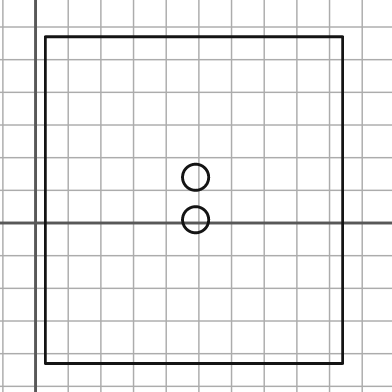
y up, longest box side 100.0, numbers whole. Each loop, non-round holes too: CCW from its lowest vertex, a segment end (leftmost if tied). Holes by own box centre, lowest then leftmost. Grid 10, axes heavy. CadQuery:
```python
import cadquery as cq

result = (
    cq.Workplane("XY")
    .moveTo(3.0, -43.0)
    .lineTo(94.0, -43.0)
    .lineTo(94.0, 57.0)
    .lineTo(3.0, 57.0)
    .close()
    .moveTo(49.0, 1.0)
    .circle(4.0)
    .moveTo(49.0, 14.0)
    .circle(4.0)
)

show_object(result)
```